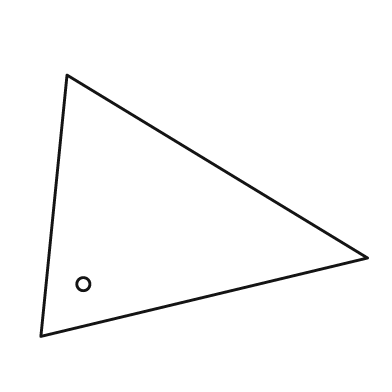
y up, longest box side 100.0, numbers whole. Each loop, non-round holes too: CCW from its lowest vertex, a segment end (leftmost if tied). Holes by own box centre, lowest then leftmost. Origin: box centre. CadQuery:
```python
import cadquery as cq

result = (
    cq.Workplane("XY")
    .moveTo(-50.0, -40.0)
    .lineTo(50.0, -16.0)
    .lineTo(-42.0, 40.0)
    .close()
    .moveTo(-37.0, -24.0)
    .circle(2.0)
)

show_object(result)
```